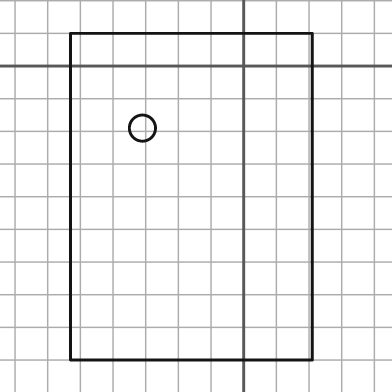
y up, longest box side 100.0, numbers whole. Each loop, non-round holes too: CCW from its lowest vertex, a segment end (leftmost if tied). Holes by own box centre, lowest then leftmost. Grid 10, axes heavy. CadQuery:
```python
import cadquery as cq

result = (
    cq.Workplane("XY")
    .moveTo(-53.0, -90.0)
    .lineTo(21.0, -90.0)
    .lineTo(21.0, 10.0)
    .lineTo(-53.0, 10.0)
    .close()
    .moveTo(-31.0, -19.0)
    .circle(4.0)
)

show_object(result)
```